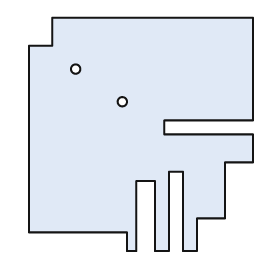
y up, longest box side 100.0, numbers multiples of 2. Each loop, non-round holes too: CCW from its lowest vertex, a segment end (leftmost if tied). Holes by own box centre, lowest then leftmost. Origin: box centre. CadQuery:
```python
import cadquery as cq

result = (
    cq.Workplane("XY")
    .moveTo(-6.0, -50.0)
    .lineTo(-2.0, -50.0)
    .lineTo(-2.0, -20.0)
    .lineTo(6.0, -20.0)
    .lineTo(6.0, -50.0)
    .lineTo(12.0, -50.0)
    .lineTo(12.0, -16.0)
    .lineTo(18.0, -16.0)
    .lineTo(18.0, -50.0)
    .lineTo(24.0, -50.0)
    .lineTo(24.0, -36.0)
    .lineTo(36.0, -36.0)
    .lineTo(36.0, -12.0)
    .lineTo(48.0, -12.0)
    .lineTo(48.0, 0.0)
    .lineTo(10.0, 0.0)
    .lineTo(10.0, 6.0)
    .lineTo(48.0, 6.0)
    .lineTo(48.0, 50.0)
    .lineTo(-38.0, 50.0)
    .lineTo(-38.0, 38.0)
    .lineTo(-48.0, 38.0)
    .lineTo(-48.0, -42.0)
    .lineTo(-6.0, -42.0)
    .close()
    .moveTo(-8.0, 14.0)
    .circle(2.0)
    .moveTo(-28.0, 28.0)
    .circle(2.0)
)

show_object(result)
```